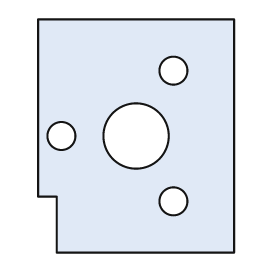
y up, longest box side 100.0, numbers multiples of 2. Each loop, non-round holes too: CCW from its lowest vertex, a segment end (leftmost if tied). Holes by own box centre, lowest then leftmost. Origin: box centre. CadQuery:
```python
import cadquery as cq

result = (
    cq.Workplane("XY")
    .moveTo(-34.0, -50.0)
    .lineTo(42.0, -50.0)
    .lineTo(42.0, 50.0)
    .lineTo(-42.0, 50.0)
    .lineTo(-42.0, -26.0)
    .lineTo(-34.0, -26.0)
    .close()
    .moveTo(16.0, -28.0)
    .circle(6.0)
    .moveTo(-32.0, 0.0)
    .circle(6.0)
    .moveTo(0.0, 0.0)
    .circle(14.0)
    .moveTo(16.0, 28.0)
    .circle(6.0)
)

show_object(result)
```